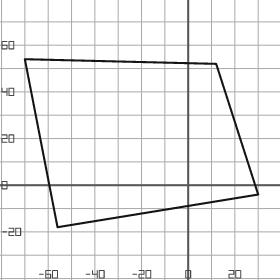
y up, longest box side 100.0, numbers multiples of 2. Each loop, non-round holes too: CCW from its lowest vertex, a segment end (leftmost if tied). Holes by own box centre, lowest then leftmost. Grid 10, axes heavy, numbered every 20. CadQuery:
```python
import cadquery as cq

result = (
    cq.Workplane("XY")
    .moveTo(-56.0, -18.0)
    .lineTo(30.0, -4.0)
    .lineTo(12.0, 52.0)
    .lineTo(-70.0, 54.0)
    .close()
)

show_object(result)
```